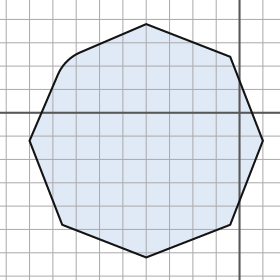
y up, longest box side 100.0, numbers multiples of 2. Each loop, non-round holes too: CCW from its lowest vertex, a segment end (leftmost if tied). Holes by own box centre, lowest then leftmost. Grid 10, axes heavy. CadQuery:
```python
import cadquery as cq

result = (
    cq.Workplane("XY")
    .moveTo(-40.0, -62.0)
    .lineTo(-4.0, -48.0)
    .lineTo(10.0, -12.0)
    .lineTo(-4.0, 24.0)
    .lineTo(-40.0, 38.0)
    .lineTo(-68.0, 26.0)
    .threePointArc((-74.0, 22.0), (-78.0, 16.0))
    .lineTo(-90.0, -12.0)
    .lineTo(-76.0, -48.0)
    .close()
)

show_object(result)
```